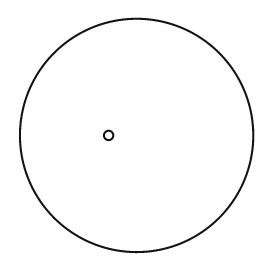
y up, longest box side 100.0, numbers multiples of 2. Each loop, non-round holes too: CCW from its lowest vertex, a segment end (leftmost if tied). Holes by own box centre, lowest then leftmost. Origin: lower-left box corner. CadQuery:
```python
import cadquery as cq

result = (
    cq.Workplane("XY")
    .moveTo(50.0, 50.0)
    .circle(50.0)
    .moveTo(38.0, 50.0)
    .circle(2.0)
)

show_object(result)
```